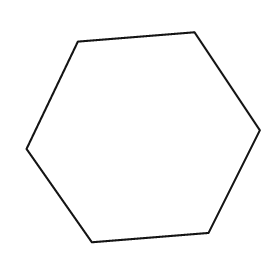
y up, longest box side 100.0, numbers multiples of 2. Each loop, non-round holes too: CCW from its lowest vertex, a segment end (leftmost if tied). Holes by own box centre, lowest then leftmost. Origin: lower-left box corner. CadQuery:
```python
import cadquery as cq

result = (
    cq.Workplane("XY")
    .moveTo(28.0, 0.0)
    .lineTo(78.0, 4.0)
    .lineTo(100.0, 48.0)
    .lineTo(72.0, 90.0)
    .lineTo(22.0, 86.0)
    .lineTo(0.0, 40.0)
    .close()
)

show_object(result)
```